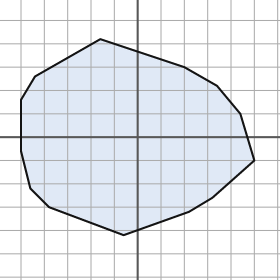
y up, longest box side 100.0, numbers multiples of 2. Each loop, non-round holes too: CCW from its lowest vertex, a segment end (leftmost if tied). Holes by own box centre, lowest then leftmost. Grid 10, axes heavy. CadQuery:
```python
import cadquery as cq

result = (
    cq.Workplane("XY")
    .moveTo(-6.0, -42.0)
    .lineTo(22.0, -32.0)
    .lineTo(32.0, -26.0)
    .lineTo(50.0, -10.0)
    .lineTo(44.0, 10.0)
    .lineTo(34.0, 22.0)
    .lineTo(20.0, 30.0)
    .lineTo(-16.0, 42.0)
    .lineTo(-44.0, 26.0)
    .lineTo(-50.0, 16.0)
    .lineTo(-50.0, -6.0)
    .lineTo(-46.0, -22.0)
    .lineTo(-38.0, -30.0)
    .close()
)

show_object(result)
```